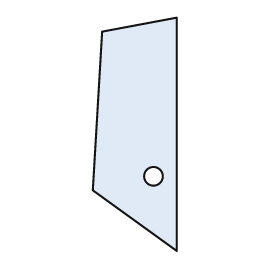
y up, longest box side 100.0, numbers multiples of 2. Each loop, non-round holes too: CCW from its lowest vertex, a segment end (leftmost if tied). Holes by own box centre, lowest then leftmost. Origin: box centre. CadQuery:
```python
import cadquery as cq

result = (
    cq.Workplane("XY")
    .moveTo(18.0, -50.0)
    .lineTo(18.0, 50.0)
    .lineTo(-14.0, 44.0)
    .lineTo(-18.0, -24.0)
    .close()
    .moveTo(8.0, -18.0)
    .circle(4.0)
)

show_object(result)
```